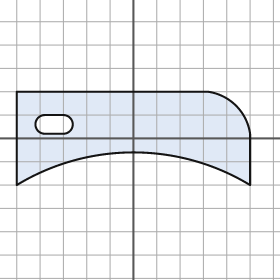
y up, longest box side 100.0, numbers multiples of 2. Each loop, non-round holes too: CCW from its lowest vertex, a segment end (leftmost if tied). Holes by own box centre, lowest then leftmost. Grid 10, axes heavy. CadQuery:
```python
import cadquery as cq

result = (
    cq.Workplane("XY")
    .moveTo(-50.0, -20.0)
    .threePointArc((0.0, -6.0), (50.0, -20.0))
    .lineTo(50.0, 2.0)
    .threePointArc((44.0, 14.0), (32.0, 20.0))
    .lineTo(-50.0, 20.0)
    .close()
    .moveTo(-38.0, 2.0)
    .lineTo(-30.0, 2.0)
    .threePointArc((-26.0, 6.0), (-30.0, 10.0))
    .lineTo(-38.0, 10.0)
    .threePointArc((-42.0, 6.0), (-38.0, 2.0))
    .close()
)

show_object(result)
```